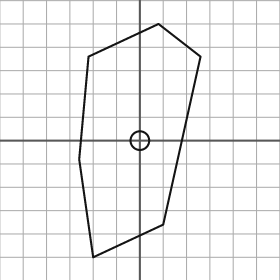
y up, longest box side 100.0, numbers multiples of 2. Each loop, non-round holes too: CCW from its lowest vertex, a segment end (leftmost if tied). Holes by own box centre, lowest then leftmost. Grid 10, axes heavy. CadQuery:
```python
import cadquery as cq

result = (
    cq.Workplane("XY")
    .moveTo(-20.0, -50.0)
    .lineTo(10.0, -36.0)
    .lineTo(26.0, 36.0)
    .lineTo(8.0, 50.0)
    .lineTo(-22.0, 36.0)
    .lineTo(-26.0, -8.0)
    .close()
    .moveTo(0.0, 0.0)
    .circle(4.0)
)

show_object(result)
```